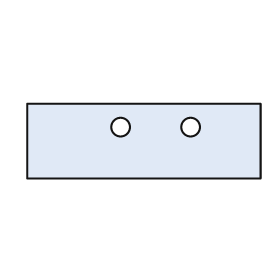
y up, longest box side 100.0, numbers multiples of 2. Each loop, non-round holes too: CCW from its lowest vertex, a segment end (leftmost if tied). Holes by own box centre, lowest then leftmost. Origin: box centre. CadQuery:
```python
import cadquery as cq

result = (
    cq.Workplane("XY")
    .moveTo(-50.0, -16.0)
    .lineTo(50.0, -16.0)
    .lineTo(50.0, 16.0)
    .lineTo(-50.0, 16.0)
    .close()
    .moveTo(-10.0, 6.0)
    .circle(4.0)
    .moveTo(20.0, 6.0)
    .circle(4.0)
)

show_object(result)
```